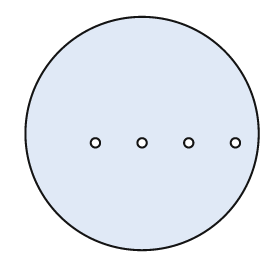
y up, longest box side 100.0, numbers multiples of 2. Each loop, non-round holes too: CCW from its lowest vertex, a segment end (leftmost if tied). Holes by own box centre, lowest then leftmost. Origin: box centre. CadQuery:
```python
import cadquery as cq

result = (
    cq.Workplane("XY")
    .moveTo(0.0, 0.0)
    .circle(50.0)
    .moveTo(-20.0, -4.0)
    .circle(2.0)
    .moveTo(0.0, -4.0)
    .circle(2.0)
    .moveTo(20.0, -4.0)
    .circle(2.0)
    .moveTo(40.0, -4.0)
    .circle(2.0)
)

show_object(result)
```